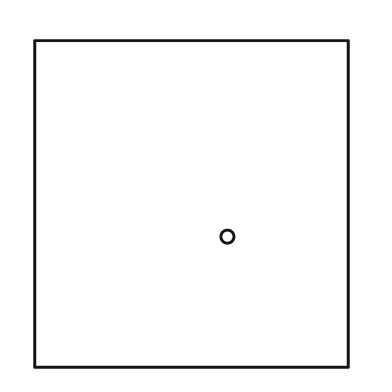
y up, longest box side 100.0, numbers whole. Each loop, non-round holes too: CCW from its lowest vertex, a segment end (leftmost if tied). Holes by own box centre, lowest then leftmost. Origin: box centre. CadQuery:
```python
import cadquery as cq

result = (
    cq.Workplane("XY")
    .moveTo(-48.0, -50.0)
    .lineTo(48.0, -50.0)
    .lineTo(48.0, 50.0)
    .lineTo(-48.0, 50.0)
    .close()
    .moveTo(11.0, -10.0)
    .circle(2.0)
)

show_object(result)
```